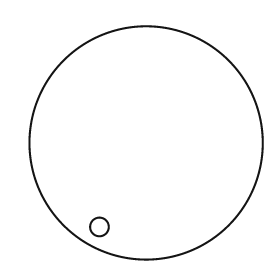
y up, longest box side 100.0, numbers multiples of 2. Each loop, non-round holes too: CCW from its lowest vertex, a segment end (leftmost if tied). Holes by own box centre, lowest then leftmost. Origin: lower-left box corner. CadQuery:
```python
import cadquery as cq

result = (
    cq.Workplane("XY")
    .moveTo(50.0, 50.0)
    .circle(50.0)
    .moveTo(30.0, 14.0)
    .circle(4.0)
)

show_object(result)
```